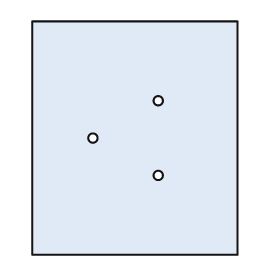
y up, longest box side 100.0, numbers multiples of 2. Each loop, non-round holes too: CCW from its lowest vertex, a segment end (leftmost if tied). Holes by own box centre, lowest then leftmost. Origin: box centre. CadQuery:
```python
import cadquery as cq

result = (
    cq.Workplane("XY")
    .moveTo(-44.0, -50.0)
    .lineTo(44.0, -50.0)
    .lineTo(44.0, 50.0)
    .lineTo(-44.0, 50.0)
    .close()
    .moveTo(10.0, -16.0)
    .circle(2.0)
    .moveTo(-18.0, 0.0)
    .circle(2.0)
    .moveTo(10.0, 16.0)
    .circle(2.0)
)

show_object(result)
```